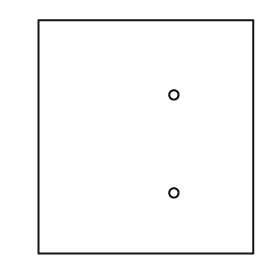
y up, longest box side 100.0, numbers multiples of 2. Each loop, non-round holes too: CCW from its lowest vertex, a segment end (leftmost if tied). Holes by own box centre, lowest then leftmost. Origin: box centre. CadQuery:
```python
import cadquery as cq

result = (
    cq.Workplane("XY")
    .moveTo(-46.0, -50.0)
    .lineTo(46.0, -50.0)
    .lineTo(46.0, 50.0)
    .lineTo(-46.0, 50.0)
    .close()
    .moveTo(12.0, -24.0)
    .circle(2.0)
    .moveTo(12.0, 18.0)
    .circle(2.0)
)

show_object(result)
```